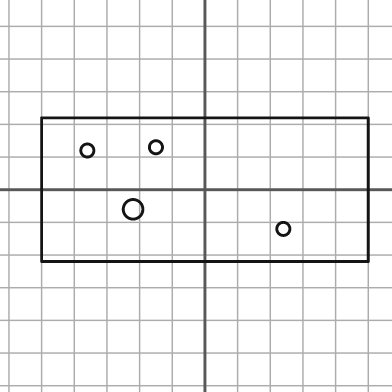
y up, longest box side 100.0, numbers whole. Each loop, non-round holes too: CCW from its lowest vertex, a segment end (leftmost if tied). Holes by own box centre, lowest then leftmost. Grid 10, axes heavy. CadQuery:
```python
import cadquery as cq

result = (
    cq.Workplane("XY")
    .moveTo(-50.0, -22.0)
    .lineTo(50.0, -22.0)
    .lineTo(50.0, 22.0)
    .lineTo(-50.0, 22.0)
    .close()
    .moveTo(24.0, -12.0)
    .circle(2.0)
    .moveTo(-22.0, -6.0)
    .circle(3.0)
    .moveTo(-36.0, 12.0)
    .circle(2.0)
    .moveTo(-15.0, 13.0)
    .circle(2.0)
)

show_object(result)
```